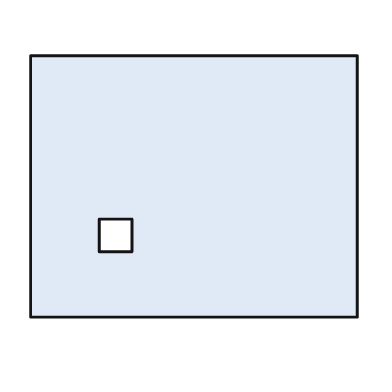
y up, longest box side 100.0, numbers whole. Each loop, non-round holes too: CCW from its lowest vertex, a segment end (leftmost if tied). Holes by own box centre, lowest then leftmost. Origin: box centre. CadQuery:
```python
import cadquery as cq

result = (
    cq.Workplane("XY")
    .moveTo(-50.0, -40.0)
    .lineTo(50.0, -40.0)
    .lineTo(50.0, 40.0)
    .lineTo(-50.0, 40.0)
    .close()
    .moveTo(-29.0, -20.0)
    .lineTo(-19.0, -20.0)
    .lineTo(-19.0, -10.0)
    .lineTo(-29.0, -10.0)
    .close()
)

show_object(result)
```